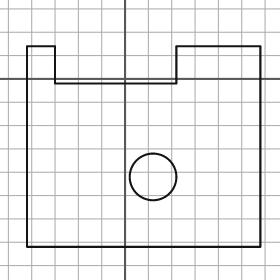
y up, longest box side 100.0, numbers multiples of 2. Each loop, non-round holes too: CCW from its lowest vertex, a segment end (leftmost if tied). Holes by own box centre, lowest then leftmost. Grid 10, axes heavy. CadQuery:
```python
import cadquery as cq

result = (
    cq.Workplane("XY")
    .moveTo(-42.0, -72.0)
    .lineTo(58.0, -72.0)
    .lineTo(58.0, 14.0)
    .lineTo(22.0, 14.0)
    .lineTo(22.0, -2.0)
    .lineTo(-30.0, -2.0)
    .lineTo(-30.0, 14.0)
    .lineTo(-42.0, 14.0)
    .close()
    .moveTo(12.0, -42.0)
    .circle(10.0)
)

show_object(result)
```